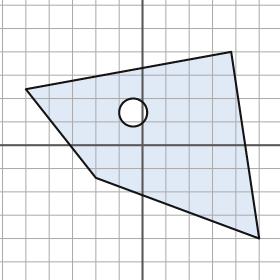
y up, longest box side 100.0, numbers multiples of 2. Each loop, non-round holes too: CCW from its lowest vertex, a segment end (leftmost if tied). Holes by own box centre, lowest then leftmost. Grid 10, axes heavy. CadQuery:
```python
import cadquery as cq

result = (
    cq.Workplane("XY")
    .moveTo(50.0, -40.0)
    .lineTo(38.0, 40.0)
    .lineTo(-50.0, 24.0)
    .lineTo(-20.0, -14.0)
    .close()
    .moveTo(-4.0, 14.0)
    .circle(6.0)
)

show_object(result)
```